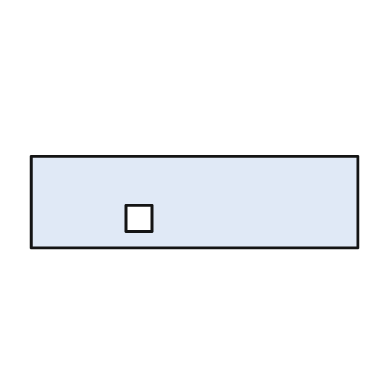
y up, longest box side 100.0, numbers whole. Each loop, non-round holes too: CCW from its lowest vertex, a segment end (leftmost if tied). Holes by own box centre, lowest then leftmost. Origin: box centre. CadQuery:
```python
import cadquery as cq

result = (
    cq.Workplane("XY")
    .moveTo(-50.0, -14.0)
    .lineTo(50.0, -14.0)
    .lineTo(50.0, 14.0)
    .lineTo(-50.0, 14.0)
    .close()
    .moveTo(-21.0, -9.0)
    .lineTo(-13.0, -9.0)
    .lineTo(-13.0, -1.0)
    .lineTo(-21.0, -1.0)
    .close()
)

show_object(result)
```